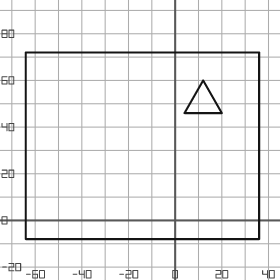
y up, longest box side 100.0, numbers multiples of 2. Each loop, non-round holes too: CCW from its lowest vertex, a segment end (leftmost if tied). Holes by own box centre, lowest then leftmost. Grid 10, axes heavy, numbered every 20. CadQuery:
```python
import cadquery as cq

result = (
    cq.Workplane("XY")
    .moveTo(-64.0, -8.0)
    .lineTo(36.0, -8.0)
    .lineTo(36.0, 72.0)
    .lineTo(-64.0, 72.0)
    .close()
    .moveTo(4.0, 46.0)
    .lineTo(20.0, 46.0)
    .lineTo(12.0, 60.0)
    .close()
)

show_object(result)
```